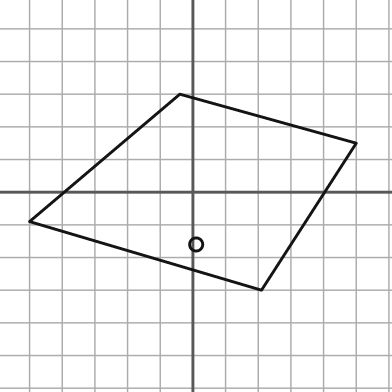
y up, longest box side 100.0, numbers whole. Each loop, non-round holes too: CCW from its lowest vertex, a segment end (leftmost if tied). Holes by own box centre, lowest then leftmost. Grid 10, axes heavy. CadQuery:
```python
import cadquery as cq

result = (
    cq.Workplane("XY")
    .moveTo(21.0, -30.0)
    .lineTo(50.0, 15.0)
    .lineTo(-4.0, 30.0)
    .lineTo(-50.0, -9.0)
    .close()
    .moveTo(1.0, -16.0)
    .circle(2.0)
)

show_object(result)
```